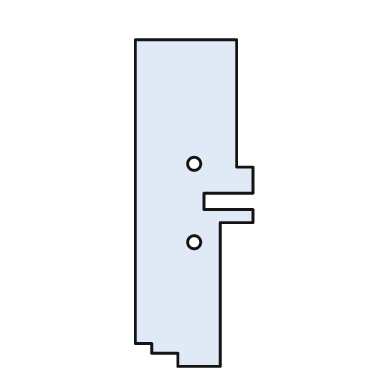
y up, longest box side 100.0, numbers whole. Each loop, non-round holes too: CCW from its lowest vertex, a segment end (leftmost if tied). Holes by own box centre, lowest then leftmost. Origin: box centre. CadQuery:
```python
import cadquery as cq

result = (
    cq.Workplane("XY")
    .moveTo(-5.0, -50.0)
    .lineTo(8.0, -50.0)
    .lineTo(8.0, -6.0)
    .lineTo(18.0, -6.0)
    .lineTo(18.0, -2.0)
    .lineTo(3.0, -2.0)
    .lineTo(3.0, 3.0)
    .lineTo(18.0, 3.0)
    .lineTo(18.0, 11.0)
    .lineTo(13.0, 11.0)
    .lineTo(13.0, 50.0)
    .lineTo(-18.0, 50.0)
    .lineTo(-18.0, -43.0)
    .lineTo(-13.0, -43.0)
    .lineTo(-13.0, -46.0)
    .lineTo(-5.0, -46.0)
    .close()
    .moveTo(0.0, -12.0)
    .circle(2.0)
    .moveTo(0.0, 12.0)
    .circle(2.0)
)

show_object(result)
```